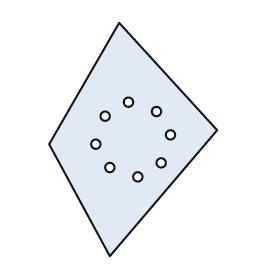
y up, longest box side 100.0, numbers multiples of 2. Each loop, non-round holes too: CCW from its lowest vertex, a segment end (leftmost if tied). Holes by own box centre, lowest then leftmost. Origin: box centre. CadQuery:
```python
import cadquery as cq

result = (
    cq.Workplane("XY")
    .moveTo(-10.0, -50.0)
    .lineTo(36.0, 4.0)
    .lineTo(-6.0, 50.0)
    .lineTo(-36.0, -2.0)
    .close()
    .moveTo(2.0, -16.0)
    .circle(2.0)
    .moveTo(-10.0, -12.0)
    .circle(2.0)
    .moveTo(12.0, -10.0)
    .circle(2.0)
    .moveTo(-16.0, -2.0)
    .circle(2.0)
    .moveTo(16.0, 2.0)
    .circle(2.0)
    .moveTo(-12.0, 10.0)
    .circle(2.0)
    .moveTo(10.0, 12.0)
    .circle(2.0)
    .moveTo(-2.0, 16.0)
    .circle(2.0)
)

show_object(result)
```